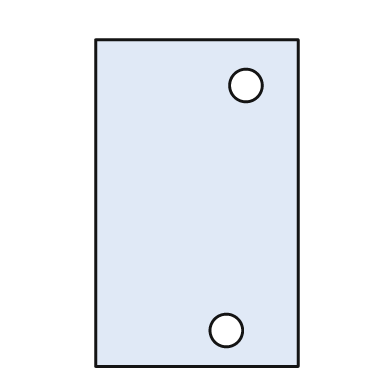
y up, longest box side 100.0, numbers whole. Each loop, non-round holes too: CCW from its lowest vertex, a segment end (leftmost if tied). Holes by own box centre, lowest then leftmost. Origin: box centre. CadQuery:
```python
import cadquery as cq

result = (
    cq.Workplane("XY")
    .moveTo(-31.0, -50.0)
    .lineTo(31.0, -50.0)
    .lineTo(31.0, 50.0)
    .lineTo(-31.0, 50.0)
    .close()
    .moveTo(9.0, -39.0)
    .circle(5.0)
    .moveTo(15.0, 36.0)
    .circle(5.0)
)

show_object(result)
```